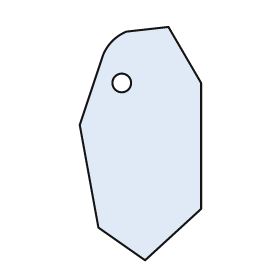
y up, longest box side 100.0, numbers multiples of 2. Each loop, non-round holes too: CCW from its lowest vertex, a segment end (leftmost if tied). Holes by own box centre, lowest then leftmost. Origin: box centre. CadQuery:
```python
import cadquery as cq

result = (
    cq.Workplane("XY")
    .moveTo(2.0, -50.0)
    .lineTo(26.0, -28.0)
    .lineTo(26.0, 26.0)
    .lineTo(12.0, 50.0)
    .lineTo(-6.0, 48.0)
    .threePointArc((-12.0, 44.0), (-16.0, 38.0))
    .lineTo(-26.0, 8.0)
    .lineTo(-18.0, -36.0)
    .close()
    .moveTo(-8.0, 26.0)
    .circle(4.0)
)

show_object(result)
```